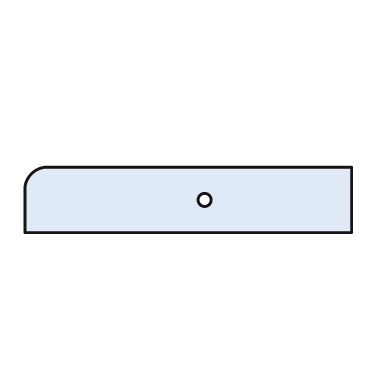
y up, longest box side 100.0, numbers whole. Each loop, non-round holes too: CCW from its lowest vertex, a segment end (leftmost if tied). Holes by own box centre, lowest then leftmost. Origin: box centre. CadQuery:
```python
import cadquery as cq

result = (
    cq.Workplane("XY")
    .moveTo(-50.0, -10.0)
    .lineTo(50.0, -10.0)
    .lineTo(50.0, 10.0)
    .lineTo(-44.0, 10.0)
    .threePointArc((-48.0, 8.0), (-50.0, 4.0))
    .close()
    .moveTo(5.0, 0.0)
    .circle(2.0)
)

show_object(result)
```